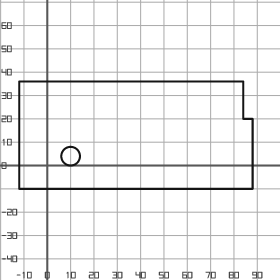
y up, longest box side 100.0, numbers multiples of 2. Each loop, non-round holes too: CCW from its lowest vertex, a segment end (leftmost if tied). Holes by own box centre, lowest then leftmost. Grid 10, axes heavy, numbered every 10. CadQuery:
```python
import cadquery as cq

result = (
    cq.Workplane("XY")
    .moveTo(-12.0, -10.0)
    .lineTo(88.0, -10.0)
    .lineTo(88.0, 20.0)
    .lineTo(84.0, 20.0)
    .lineTo(84.0, 36.0)
    .lineTo(-12.0, 36.0)
    .close()
    .moveTo(10.0, 4.0)
    .circle(4.0)
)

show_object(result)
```